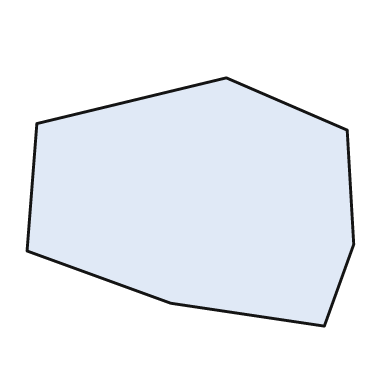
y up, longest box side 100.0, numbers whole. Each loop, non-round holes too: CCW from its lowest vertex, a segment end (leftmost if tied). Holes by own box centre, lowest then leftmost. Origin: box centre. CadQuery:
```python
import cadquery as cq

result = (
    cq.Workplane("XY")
    .moveTo(41.0, -38.0)
    .lineTo(50.0, -13.0)
    .lineTo(48.0, 22.0)
    .lineTo(11.0, 38.0)
    .lineTo(-47.0, 24.0)
    .lineTo(-50.0, -15.0)
    .lineTo(-6.0, -31.0)
    .close()
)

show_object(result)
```